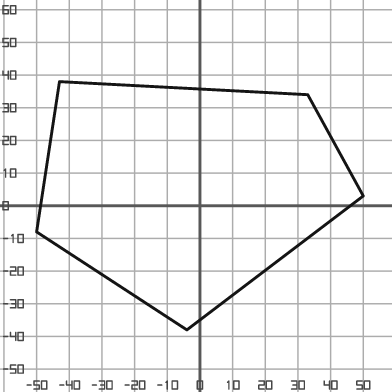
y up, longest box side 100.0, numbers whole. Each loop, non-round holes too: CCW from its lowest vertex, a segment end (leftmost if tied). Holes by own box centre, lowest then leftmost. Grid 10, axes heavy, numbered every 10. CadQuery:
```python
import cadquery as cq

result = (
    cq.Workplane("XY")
    .moveTo(-4.0, -38.0)
    .lineTo(50.0, 3.0)
    .lineTo(33.0, 34.0)
    .lineTo(-43.0, 38.0)
    .lineTo(-50.0, -8.0)
    .close()
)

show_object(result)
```